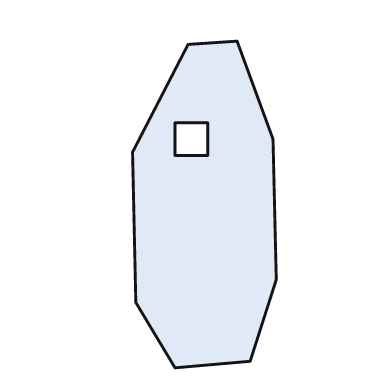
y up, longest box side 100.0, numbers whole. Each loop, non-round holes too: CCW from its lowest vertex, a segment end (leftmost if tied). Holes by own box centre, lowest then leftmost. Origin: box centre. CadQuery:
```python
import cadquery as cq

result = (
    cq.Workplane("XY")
    .moveTo(-9.0, -50.0)
    .lineTo(14.0, -48.0)
    .lineTo(22.0, -23.0)
    .lineTo(21.0, 20.0)
    .lineTo(10.0, 50.0)
    .lineTo(-5.0, 49.0)
    .lineTo(-22.0, 16.0)
    .lineTo(-21.0, -30.0)
    .close()
    .moveTo(-9.0, 15.0)
    .lineTo(1.0, 15.0)
    .lineTo(1.0, 25.0)
    .lineTo(-9.0, 25.0)
    .close()
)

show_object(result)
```